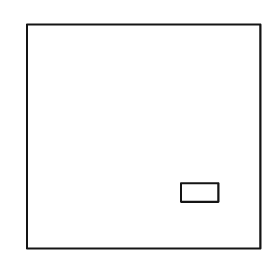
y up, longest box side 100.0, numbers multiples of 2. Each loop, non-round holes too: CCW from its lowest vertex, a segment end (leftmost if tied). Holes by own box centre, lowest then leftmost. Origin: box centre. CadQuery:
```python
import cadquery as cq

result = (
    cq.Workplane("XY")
    .moveTo(-50.0, -48.0)
    .lineTo(50.0, -48.0)
    .lineTo(50.0, 48.0)
    .lineTo(-50.0, 48.0)
    .close()
    .moveTo(16.0, -28.0)
    .lineTo(32.0, -28.0)
    .lineTo(32.0, -20.0)
    .lineTo(16.0, -20.0)
    .close()
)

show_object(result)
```